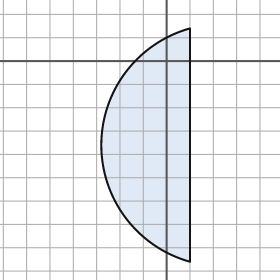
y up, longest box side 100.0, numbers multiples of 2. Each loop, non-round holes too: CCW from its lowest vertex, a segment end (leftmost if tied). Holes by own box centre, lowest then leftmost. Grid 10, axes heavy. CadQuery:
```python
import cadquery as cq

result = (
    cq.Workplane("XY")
    .moveTo(10.0, -86.0)
    .lineTo(10.0, 14.0)
    .threePointArc((-28.0, -36.0), (10.0, -86.0))
    .close()
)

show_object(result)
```